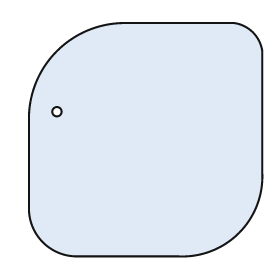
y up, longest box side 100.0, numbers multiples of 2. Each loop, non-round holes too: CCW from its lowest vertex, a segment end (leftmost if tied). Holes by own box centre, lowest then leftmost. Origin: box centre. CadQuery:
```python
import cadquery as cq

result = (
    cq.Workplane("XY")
    .moveTo(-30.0, -50.0)
    .lineTo(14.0, -50.0)
    .threePointArc((40.0, -40.0), (50.0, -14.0))
    .lineTo(50.0, 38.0)
    .threePointArc((46.0, 46.0), (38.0, 50.0))
    .lineTo(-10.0, 50.0)
    .threePointArc((-38.0, 38.0), (-50.0, 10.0))
    .lineTo(-50.0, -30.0)
    .threePointArc((-44.0, -44.0), (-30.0, -50.0))
    .close()
    .moveTo(-38.0, 12.0)
    .circle(2.0)
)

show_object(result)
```